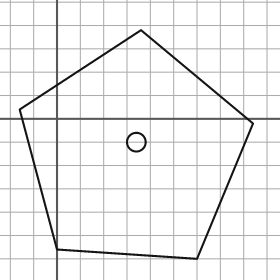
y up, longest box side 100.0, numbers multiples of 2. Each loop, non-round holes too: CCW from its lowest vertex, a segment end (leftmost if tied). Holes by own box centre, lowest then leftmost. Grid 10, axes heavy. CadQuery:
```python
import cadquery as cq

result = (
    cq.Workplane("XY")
    .moveTo(60.0, -60.0)
    .lineTo(84.0, -2.0)
    .lineTo(36.0, 38.0)
    .lineTo(-16.0, 4.0)
    .lineTo(0.0, -56.0)
    .close()
    .moveTo(34.0, -10.0)
    .circle(4.0)
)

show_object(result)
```